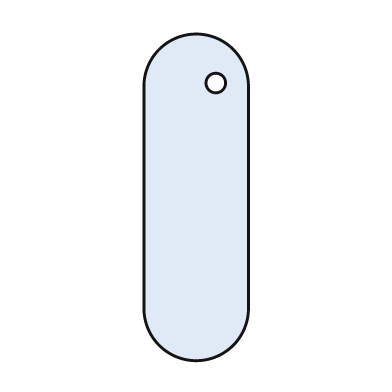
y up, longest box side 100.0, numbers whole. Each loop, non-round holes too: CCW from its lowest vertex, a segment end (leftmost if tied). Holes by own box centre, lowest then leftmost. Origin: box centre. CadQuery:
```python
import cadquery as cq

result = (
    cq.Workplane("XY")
    .moveTo(-16.0, -34.0)
    .threePointArc((0.0, -50.0), (16.0, -34.0))
    .lineTo(16.0, 34.0)
    .threePointArc((0.0, 50.0), (-16.0, 34.0))
    .close()
    .moveTo(6.0, 35.0)
    .circle(3.0)
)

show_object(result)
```